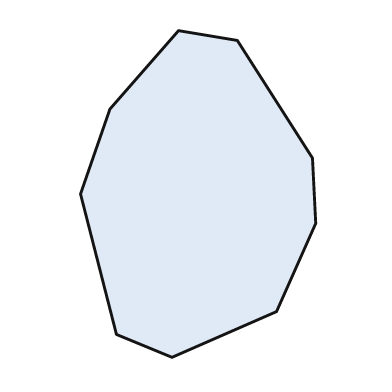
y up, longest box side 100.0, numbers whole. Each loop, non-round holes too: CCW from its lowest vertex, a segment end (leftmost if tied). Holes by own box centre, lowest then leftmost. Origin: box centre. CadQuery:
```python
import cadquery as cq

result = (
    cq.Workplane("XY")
    .moveTo(-8.0, -50.0)
    .lineTo(24.0, -36.0)
    .lineTo(36.0, -9.0)
    .lineTo(35.0, 11.0)
    .lineTo(12.0, 47.0)
    .lineTo(-6.0, 50.0)
    .lineTo(-27.0, 26.0)
    .lineTo(-36.0, 0.0)
    .lineTo(-25.0, -43.0)
    .close()
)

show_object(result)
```